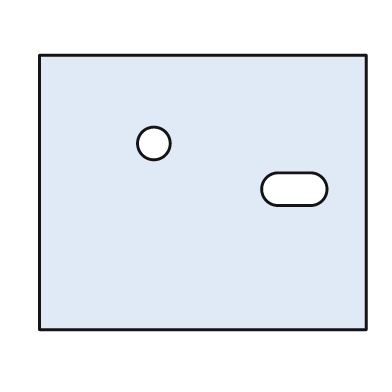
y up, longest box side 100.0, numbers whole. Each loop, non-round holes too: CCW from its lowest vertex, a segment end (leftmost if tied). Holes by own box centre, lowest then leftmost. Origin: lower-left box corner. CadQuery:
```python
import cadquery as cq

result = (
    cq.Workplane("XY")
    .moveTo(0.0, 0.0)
    .lineTo(100.0, 0.0)
    .lineTo(100.0, 84.0)
    .lineTo(0.0, 84.0)
    .close()
    .moveTo(73.0, 38.0)
    .lineTo(83.0, 38.0)
    .threePointArc((88.0, 43.0), (83.0, 48.0))
    .lineTo(73.0, 48.0)
    .threePointArc((68.0, 43.0), (73.0, 38.0))
    .close()
    .moveTo(35.0, 57.0)
    .circle(5.0)
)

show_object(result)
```